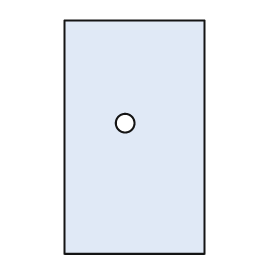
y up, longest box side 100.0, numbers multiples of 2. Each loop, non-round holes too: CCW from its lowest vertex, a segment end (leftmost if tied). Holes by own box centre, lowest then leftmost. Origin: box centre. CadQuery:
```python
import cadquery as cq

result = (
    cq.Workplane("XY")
    .moveTo(-30.0, -50.0)
    .lineTo(30.0, -50.0)
    .lineTo(30.0, 50.0)
    .lineTo(-30.0, 50.0)
    .close()
    .moveTo(-4.0, 6.0)
    .circle(4.0)
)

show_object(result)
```